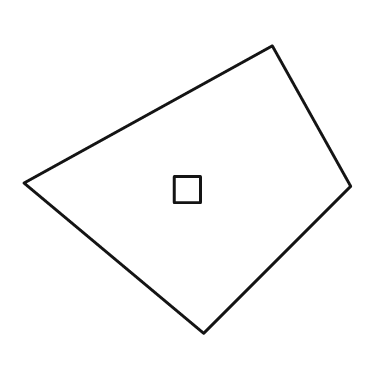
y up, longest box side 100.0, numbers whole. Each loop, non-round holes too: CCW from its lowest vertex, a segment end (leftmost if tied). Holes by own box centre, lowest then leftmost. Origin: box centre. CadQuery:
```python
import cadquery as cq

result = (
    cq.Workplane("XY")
    .moveTo(5.0, -44.0)
    .lineTo(50.0, 1.0)
    .lineTo(26.0, 44.0)
    .lineTo(-50.0, 2.0)
    .close()
    .moveTo(-4.0, -4.0)
    .lineTo(4.0, -4.0)
    .lineTo(4.0, 4.0)
    .lineTo(-4.0, 4.0)
    .close()
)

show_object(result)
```